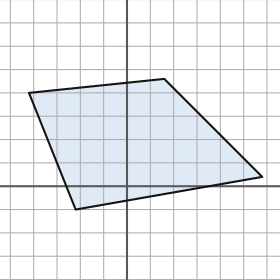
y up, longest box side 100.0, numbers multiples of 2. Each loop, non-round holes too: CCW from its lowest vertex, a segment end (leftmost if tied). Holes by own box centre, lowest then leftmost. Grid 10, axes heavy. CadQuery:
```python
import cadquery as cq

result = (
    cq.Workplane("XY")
    .moveTo(-22.0, -10.0)
    .lineTo(58.0, 4.0)
    .lineTo(16.0, 46.0)
    .lineTo(-42.0, 40.0)
    .close()
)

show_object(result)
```